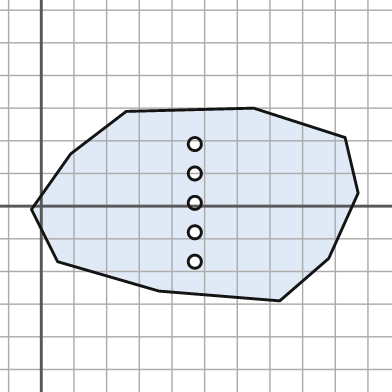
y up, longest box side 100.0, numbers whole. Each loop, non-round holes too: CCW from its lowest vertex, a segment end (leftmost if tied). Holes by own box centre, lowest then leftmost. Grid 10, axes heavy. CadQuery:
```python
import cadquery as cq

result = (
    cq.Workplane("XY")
    .moveTo(73.0, -29.0)
    .lineTo(88.0, -16.0)
    .lineTo(97.0, 4.0)
    .lineTo(93.0, 21.0)
    .lineTo(65.0, 30.0)
    .lineTo(26.0, 29.0)
    .lineTo(9.0, 16.0)
    .lineTo(-3.0, -1.0)
    .lineTo(5.0, -17.0)
    .lineTo(36.0, -26.0)
    .close()
    .moveTo(47.0, -17.0)
    .circle(2.0)
    .moveTo(47.0, -8.0)
    .circle(2.0)
    .moveTo(47.0, 1.0)
    .circle(2.0)
    .moveTo(47.0, 10.0)
    .circle(2.0)
    .moveTo(47.0, 19.0)
    .circle(2.0)
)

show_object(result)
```